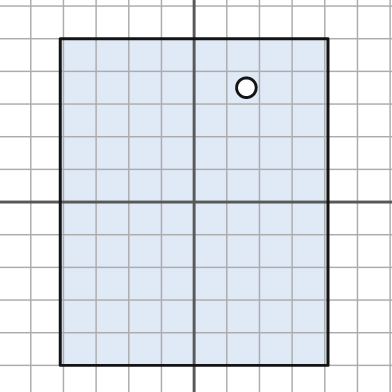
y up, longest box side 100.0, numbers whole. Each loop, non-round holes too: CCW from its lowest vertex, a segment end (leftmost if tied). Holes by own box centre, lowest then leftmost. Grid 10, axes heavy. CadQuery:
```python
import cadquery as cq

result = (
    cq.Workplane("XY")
    .moveTo(-41.0, -50.0)
    .lineTo(41.0, -50.0)
    .lineTo(41.0, 50.0)
    .lineTo(-41.0, 50.0)
    .close()
    .moveTo(16.0, 35.0)
    .circle(3.0)
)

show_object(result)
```